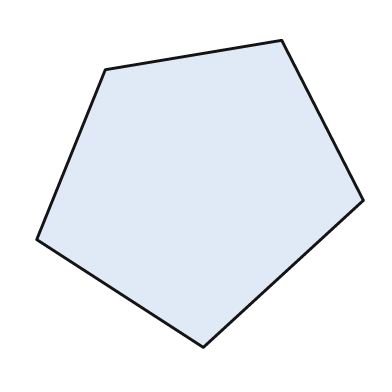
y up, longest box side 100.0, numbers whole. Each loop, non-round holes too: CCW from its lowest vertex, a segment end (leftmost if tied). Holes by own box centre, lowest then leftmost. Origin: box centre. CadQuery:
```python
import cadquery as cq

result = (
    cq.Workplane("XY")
    .moveTo(1.0, -47.0)
    .lineTo(50.0, -2.0)
    .lineTo(25.0, 47.0)
    .lineTo(-29.0, 38.0)
    .lineTo(-50.0, -14.0)
    .close()
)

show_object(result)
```